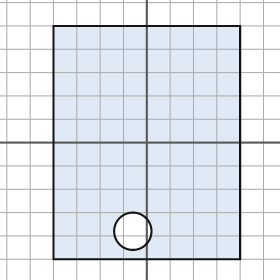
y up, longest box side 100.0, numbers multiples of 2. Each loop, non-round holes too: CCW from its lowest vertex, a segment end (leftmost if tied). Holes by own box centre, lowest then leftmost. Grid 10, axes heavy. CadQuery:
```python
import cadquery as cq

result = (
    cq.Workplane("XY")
    .moveTo(-40.0, -50.0)
    .lineTo(40.0, -50.0)
    .lineTo(40.0, 50.0)
    .lineTo(-40.0, 50.0)
    .close()
    .moveTo(-6.0, -38.0)
    .circle(8.0)
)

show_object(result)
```